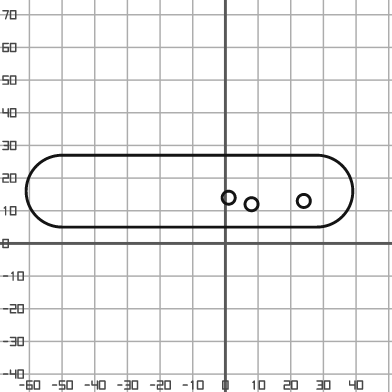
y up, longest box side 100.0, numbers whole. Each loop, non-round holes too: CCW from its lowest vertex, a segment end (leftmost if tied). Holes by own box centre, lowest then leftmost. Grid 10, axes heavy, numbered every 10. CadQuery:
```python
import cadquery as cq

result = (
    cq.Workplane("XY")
    .moveTo(-50.0, 5.0)
    .lineTo(28.0, 5.0)
    .threePointArc((39.0, 16.0), (28.0, 27.0))
    .lineTo(-50.0, 27.0)
    .threePointArc((-61.0, 16.0), (-50.0, 5.0))
    .close()
    .moveTo(8.0, 12.0)
    .circle(2.0)
    .moveTo(24.0, 13.0)
    .circle(2.0)
    .moveTo(1.0, 14.0)
    .circle(2.0)
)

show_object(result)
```